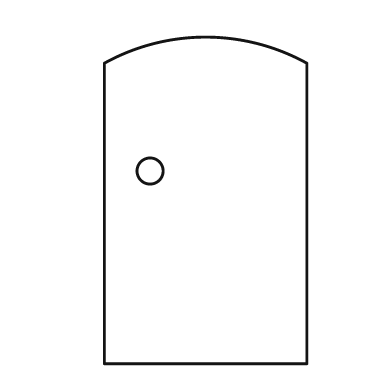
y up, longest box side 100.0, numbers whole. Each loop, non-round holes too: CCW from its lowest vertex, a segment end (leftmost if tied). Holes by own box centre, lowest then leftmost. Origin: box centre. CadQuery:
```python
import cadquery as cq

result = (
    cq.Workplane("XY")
    .moveTo(-31.0, -50.0)
    .lineTo(31.0, -50.0)
    .lineTo(31.0, 42.0)
    .threePointArc((0.0, 50.0), (-31.0, 42.0))
    .close()
    .moveTo(-17.0, 9.0)
    .circle(4.0)
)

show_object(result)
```